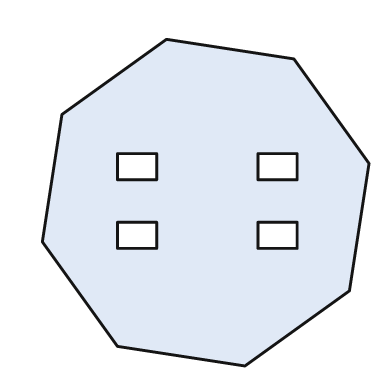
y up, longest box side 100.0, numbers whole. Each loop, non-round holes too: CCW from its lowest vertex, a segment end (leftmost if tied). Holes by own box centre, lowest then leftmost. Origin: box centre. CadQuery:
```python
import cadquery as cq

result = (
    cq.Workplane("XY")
    .moveTo(12.0, -50.0)
    .lineTo(44.0, -27.0)
    .lineTo(50.0, 12.0)
    .lineTo(27.0, 44.0)
    .lineTo(-12.0, 50.0)
    .lineTo(-44.0, 27.0)
    .lineTo(-50.0, -12.0)
    .lineTo(-27.0, -44.0)
    .close()
    .moveTo(-27.0, -14.0)
    .lineTo(-15.0, -14.0)
    .lineTo(-15.0, -6.0)
    .lineTo(-27.0, -6.0)
    .close()
    .moveTo(16.0, -14.0)
    .lineTo(28.0, -14.0)
    .lineTo(28.0, -6.0)
    .lineTo(16.0, -6.0)
    .close()
    .moveTo(-27.0, 7.0)
    .lineTo(-15.0, 7.0)
    .lineTo(-15.0, 15.0)
    .lineTo(-27.0, 15.0)
    .close()
    .moveTo(16.0, 7.0)
    .lineTo(28.0, 7.0)
    .lineTo(28.0, 15.0)
    .lineTo(16.0, 15.0)
    .close()
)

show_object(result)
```